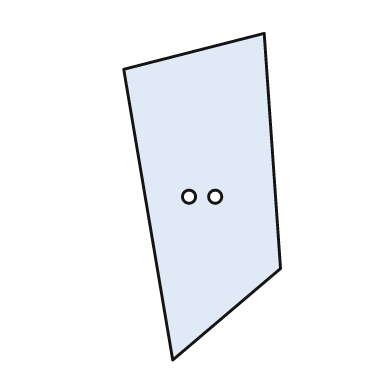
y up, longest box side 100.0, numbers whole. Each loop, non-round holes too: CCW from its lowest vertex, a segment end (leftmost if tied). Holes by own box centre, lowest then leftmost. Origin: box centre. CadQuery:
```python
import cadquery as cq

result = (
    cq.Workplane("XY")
    .moveTo(-9.0, -50.0)
    .lineTo(24.0, -22.0)
    .lineTo(19.0, 50.0)
    .lineTo(-24.0, 39.0)
    .close()
    .moveTo(-4.0, 0.0)
    .circle(2.0)
    .moveTo(4.0, 0.0)
    .circle(2.0)
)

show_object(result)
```